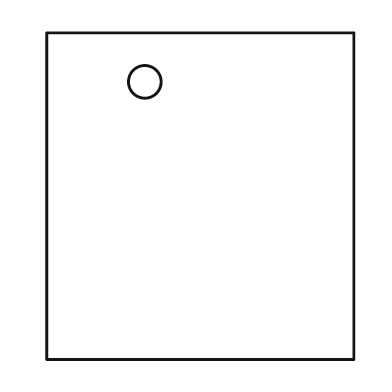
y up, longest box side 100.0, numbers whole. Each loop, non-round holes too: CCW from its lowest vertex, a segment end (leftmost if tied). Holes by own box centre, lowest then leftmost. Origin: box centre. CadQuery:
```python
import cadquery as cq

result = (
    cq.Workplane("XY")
    .moveTo(-47.0, -50.0)
    .lineTo(47.0, -50.0)
    .lineTo(47.0, 50.0)
    .lineTo(-47.0, 50.0)
    .close()
    .moveTo(-17.0, 35.0)
    .circle(5.0)
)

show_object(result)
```